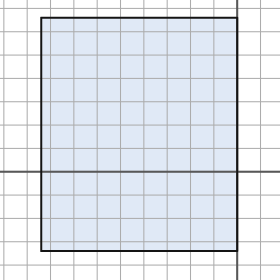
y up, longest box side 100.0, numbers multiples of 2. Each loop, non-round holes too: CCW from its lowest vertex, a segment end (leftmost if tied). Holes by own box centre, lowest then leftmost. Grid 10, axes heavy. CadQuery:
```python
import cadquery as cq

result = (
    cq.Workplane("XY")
    .moveTo(-84.0, -34.0)
    .lineTo(0.0, -34.0)
    .lineTo(0.0, 66.0)
    .lineTo(-84.0, 66.0)
    .close()
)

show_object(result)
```